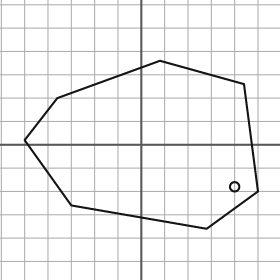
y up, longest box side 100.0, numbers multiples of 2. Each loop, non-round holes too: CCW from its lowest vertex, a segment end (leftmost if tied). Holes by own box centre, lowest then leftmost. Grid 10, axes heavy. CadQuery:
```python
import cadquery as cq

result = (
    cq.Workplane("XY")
    .moveTo(28.0, -36.0)
    .lineTo(50.0, -20.0)
    .lineTo(44.0, 26.0)
    .lineTo(8.0, 36.0)
    .lineTo(-36.0, 20.0)
    .lineTo(-50.0, 2.0)
    .lineTo(-30.0, -26.0)
    .close()
    .moveTo(40.0, -18.0)
    .circle(2.0)
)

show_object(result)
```